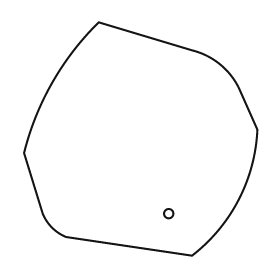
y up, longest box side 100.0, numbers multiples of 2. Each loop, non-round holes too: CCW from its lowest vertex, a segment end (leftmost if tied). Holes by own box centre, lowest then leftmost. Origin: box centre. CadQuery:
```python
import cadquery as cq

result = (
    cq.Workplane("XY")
    .moveTo(22.0, -50.0)
    .threePointArc((42.0, -26.0), (50.0, 4.0))
    .lineTo(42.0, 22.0)
    .threePointArc((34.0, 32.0), (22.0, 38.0))
    .lineTo(-18.0, 50.0)
    .threePointArc((-38.0, 24.0), (-50.0, -6.0))
    .lineTo(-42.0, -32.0)
    .threePointArc((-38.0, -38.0), (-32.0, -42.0))
    .close()
    .moveTo(12.0, -32.0)
    .circle(2.0)
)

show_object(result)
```